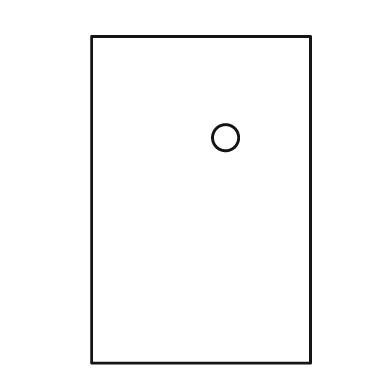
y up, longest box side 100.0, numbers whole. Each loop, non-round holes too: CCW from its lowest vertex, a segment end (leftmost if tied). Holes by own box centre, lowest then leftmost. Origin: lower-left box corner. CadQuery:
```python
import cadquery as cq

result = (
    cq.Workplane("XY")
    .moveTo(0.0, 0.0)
    .lineTo(67.0, 0.0)
    .lineTo(67.0, 100.0)
    .lineTo(0.0, 100.0)
    .close()
    .moveTo(41.0, 69.0)
    .circle(4.0)
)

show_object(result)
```